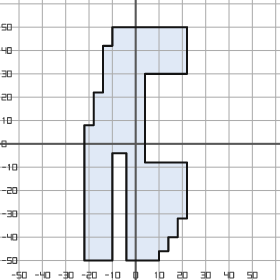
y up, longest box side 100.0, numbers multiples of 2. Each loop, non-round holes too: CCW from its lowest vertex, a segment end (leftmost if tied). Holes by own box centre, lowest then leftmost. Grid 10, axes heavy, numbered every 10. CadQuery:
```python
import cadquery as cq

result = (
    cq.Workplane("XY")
    .moveTo(-22.0, -50.0)
    .lineTo(-10.0, -50.0)
    .lineTo(-10.0, -4.0)
    .lineTo(-4.0, -4.0)
    .lineTo(-4.0, -50.0)
    .lineTo(10.0, -50.0)
    .lineTo(10.0, -46.0)
    .lineTo(14.0, -46.0)
    .lineTo(14.0, -40.0)
    .lineTo(18.0, -40.0)
    .lineTo(18.0, -32.0)
    .lineTo(22.0, -32.0)
    .lineTo(22.0, -8.0)
    .lineTo(4.0, -8.0)
    .lineTo(4.0, 30.0)
    .lineTo(22.0, 30.0)
    .lineTo(22.0, 50.0)
    .lineTo(-10.0, 50.0)
    .lineTo(-10.0, 42.0)
    .lineTo(-14.0, 42.0)
    .lineTo(-14.0, 22.0)
    .lineTo(-18.0, 22.0)
    .lineTo(-18.0, 8.0)
    .lineTo(-22.0, 8.0)
    .close()
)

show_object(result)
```